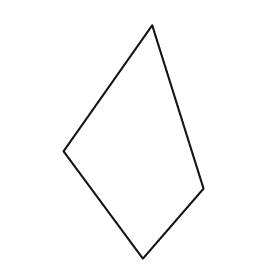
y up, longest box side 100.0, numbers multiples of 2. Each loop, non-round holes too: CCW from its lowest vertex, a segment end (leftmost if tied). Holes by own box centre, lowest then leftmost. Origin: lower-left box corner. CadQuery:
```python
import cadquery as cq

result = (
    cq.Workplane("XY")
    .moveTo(34.0, 0.0)
    .lineTo(60.0, 30.0)
    .lineTo(38.0, 100.0)
    .lineTo(0.0, 46.0)
    .close()
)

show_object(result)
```